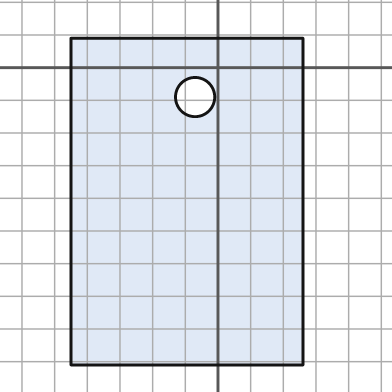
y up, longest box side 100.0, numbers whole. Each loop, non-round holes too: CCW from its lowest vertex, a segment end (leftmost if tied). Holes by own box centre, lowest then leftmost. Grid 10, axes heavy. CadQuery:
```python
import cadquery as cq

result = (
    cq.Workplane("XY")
    .moveTo(-45.0, -91.0)
    .lineTo(26.0, -91.0)
    .lineTo(26.0, 9.0)
    .lineTo(-45.0, 9.0)
    .close()
    .moveTo(-7.0, -9.0)
    .circle(6.0)
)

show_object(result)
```